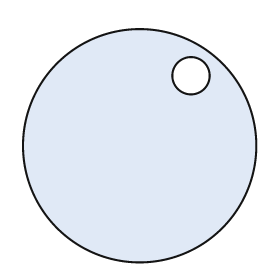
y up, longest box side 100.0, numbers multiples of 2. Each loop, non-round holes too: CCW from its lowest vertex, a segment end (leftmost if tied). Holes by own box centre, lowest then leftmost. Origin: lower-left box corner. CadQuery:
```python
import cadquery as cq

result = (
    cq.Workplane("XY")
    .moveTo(50.0, 50.0)
    .circle(50.0)
    .moveTo(72.0, 80.0)
    .circle(8.0)
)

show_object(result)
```